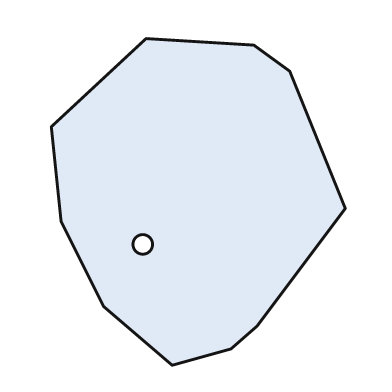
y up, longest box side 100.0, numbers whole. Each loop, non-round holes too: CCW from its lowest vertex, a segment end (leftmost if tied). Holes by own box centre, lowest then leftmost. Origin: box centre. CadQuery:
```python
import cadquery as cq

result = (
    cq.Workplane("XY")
    .moveTo(-8.0, -50.0)
    .lineTo(10.0, -45.0)
    .lineTo(18.0, -38.0)
    .lineTo(45.0, -2.0)
    .lineTo(28.0, 40.0)
    .lineTo(17.0, 48.0)
    .lineTo(-16.0, 50.0)
    .lineTo(-45.0, 23.0)
    .lineTo(-42.0, -6.0)
    .lineTo(-29.0, -32.0)
    .close()
    .moveTo(-17.0, -13.0)
    .circle(3.0)
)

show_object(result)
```